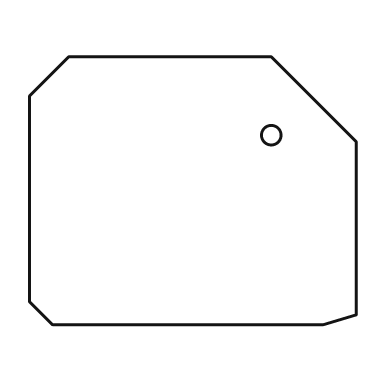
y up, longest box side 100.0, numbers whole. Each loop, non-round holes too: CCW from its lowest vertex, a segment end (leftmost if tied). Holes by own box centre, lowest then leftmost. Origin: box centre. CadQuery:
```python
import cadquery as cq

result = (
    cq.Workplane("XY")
    .moveTo(-43.0, -41.0)
    .lineTo(40.0, -41.0)
    .lineTo(50.0, -38.0)
    .lineTo(50.0, 15.0)
    .lineTo(24.0, 41.0)
    .lineTo(-38.0, 41.0)
    .lineTo(-50.0, 29.0)
    .lineTo(-50.0, -34.0)
    .close()
    .moveTo(24.0, 17.0)
    .circle(3.0)
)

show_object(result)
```